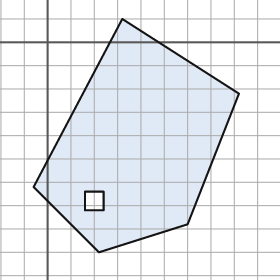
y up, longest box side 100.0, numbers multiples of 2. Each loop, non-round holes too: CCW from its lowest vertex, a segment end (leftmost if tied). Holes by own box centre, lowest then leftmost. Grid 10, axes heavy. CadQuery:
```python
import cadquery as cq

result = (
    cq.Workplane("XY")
    .moveTo(22.0, -90.0)
    .lineTo(60.0, -78.0)
    .lineTo(82.0, -22.0)
    .lineTo(32.0, 10.0)
    .lineTo(-6.0, -62.0)
    .close()
    .moveTo(16.0, -72.0)
    .lineTo(24.0, -72.0)
    .lineTo(24.0, -64.0)
    .lineTo(16.0, -64.0)
    .close()
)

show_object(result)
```